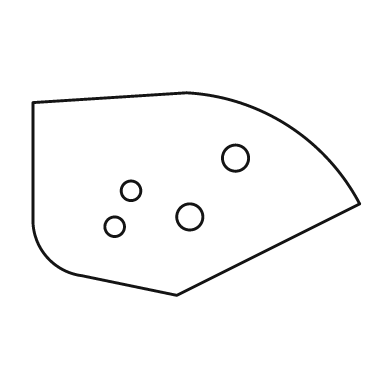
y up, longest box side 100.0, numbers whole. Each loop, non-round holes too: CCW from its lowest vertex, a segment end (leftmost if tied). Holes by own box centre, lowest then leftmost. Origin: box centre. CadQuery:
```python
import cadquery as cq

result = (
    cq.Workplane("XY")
    .moveTo(-6.0, -31.0)
    .lineTo(50.0, -3.0)
    .threePointArc((28.0, 21.0), (-3.0, 31.0))
    .lineTo(-50.0, 28.0)
    .lineTo(-50.0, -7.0)
    .threePointArc((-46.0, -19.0), (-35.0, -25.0))
    .close()
    .moveTo(-25.0, -10.0)
    .circle(3.0)
    .moveTo(-2.0, -7.0)
    .circle(4.0)
    .moveTo(-20.0, 1.0)
    .circle(3.0)
    .moveTo(12.0, 11.0)
    .circle(4.0)
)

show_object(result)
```